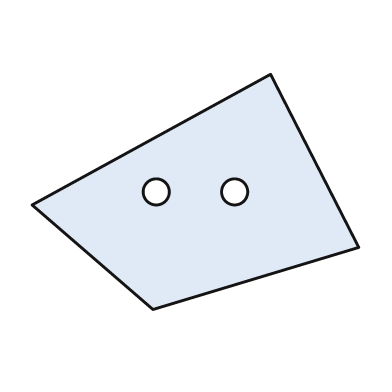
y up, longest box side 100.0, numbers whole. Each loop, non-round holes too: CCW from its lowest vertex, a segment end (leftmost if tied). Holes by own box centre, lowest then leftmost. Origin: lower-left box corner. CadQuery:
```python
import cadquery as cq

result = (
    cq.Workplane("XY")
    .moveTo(37.0, 0.0)
    .lineTo(100.0, 19.0)
    .lineTo(73.0, 72.0)
    .lineTo(0.0, 32.0)
    .close()
    .moveTo(38.0, 36.0)
    .circle(4.0)
    .moveTo(62.0, 36.0)
    .circle(4.0)
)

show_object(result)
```